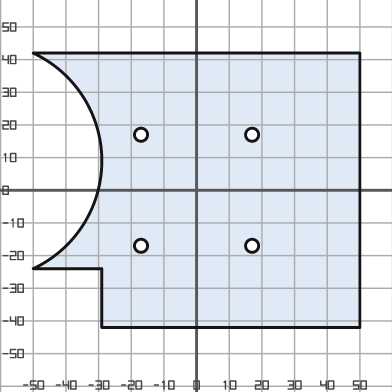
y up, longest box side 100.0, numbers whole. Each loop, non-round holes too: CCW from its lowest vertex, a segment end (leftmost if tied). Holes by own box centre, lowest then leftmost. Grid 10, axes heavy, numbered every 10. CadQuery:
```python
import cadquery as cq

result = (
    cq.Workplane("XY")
    .moveTo(-29.0, -42.0)
    .lineTo(50.0, -42.0)
    .lineTo(50.0, 42.0)
    .lineTo(-50.0, 42.0)
    .threePointArc((-29.0, 9.0), (-50.0, -24.0))
    .lineTo(-29.0, -24.0)
    .close()
    .moveTo(-17.0, -17.0)
    .circle(2.0)
    .moveTo(17.0, -17.0)
    .circle(2.0)
    .moveTo(-17.0, 17.0)
    .circle(2.0)
    .moveTo(17.0, 17.0)
    .circle(2.0)
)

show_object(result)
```